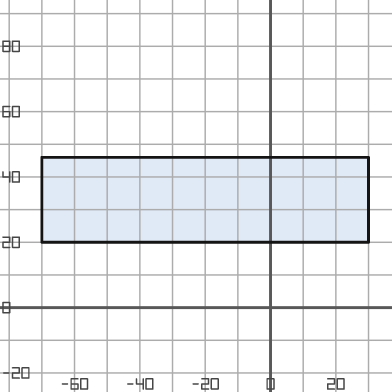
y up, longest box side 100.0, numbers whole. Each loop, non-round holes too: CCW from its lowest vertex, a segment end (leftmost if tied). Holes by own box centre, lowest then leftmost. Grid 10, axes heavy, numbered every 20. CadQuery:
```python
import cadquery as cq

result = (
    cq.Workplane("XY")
    .moveTo(-70.0, 20.0)
    .lineTo(30.0, 20.0)
    .lineTo(30.0, 46.0)
    .lineTo(-70.0, 46.0)
    .close()
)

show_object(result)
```